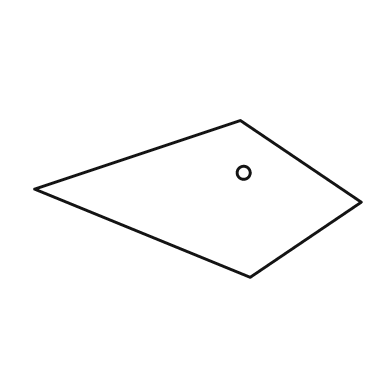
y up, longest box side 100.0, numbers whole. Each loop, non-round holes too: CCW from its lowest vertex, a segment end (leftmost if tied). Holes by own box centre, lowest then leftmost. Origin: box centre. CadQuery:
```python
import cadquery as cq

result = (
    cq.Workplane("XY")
    .moveTo(16.0, -24.0)
    .lineTo(50.0, -1.0)
    .lineTo(13.0, 24.0)
    .lineTo(-50.0, 3.0)
    .close()
    .moveTo(14.0, 8.0)
    .circle(2.0)
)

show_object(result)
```